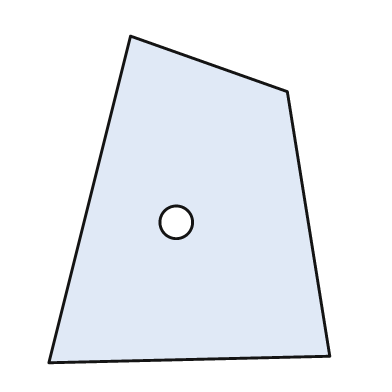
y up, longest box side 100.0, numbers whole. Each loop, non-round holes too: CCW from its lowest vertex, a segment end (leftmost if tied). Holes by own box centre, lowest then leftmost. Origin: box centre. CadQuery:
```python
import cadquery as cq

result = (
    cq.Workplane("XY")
    .moveTo(-43.0, -50.0)
    .lineTo(43.0, -48.0)
    .lineTo(30.0, 33.0)
    .lineTo(-18.0, 50.0)
    .close()
    .moveTo(-4.0, -7.0)
    .circle(5.0)
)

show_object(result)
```